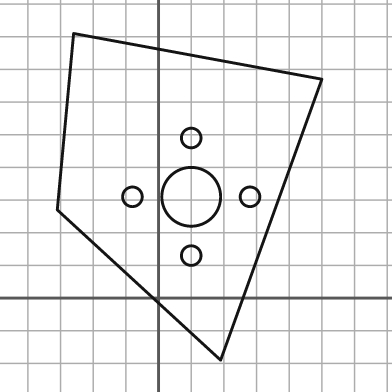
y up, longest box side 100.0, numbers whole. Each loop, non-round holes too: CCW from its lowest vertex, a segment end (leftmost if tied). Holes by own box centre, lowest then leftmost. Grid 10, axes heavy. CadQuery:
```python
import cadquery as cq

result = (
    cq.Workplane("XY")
    .moveTo(19.0, -19.0)
    .lineTo(50.0, 67.0)
    .lineTo(-26.0, 81.0)
    .lineTo(-31.0, 27.0)
    .close()
    .moveTo(10.0, 13.0)
    .circle(3.0)
    .moveTo(-8.0, 31.0)
    .circle(3.0)
    .moveTo(10.0, 31.0)
    .circle(9.0)
    .moveTo(28.0, 31.0)
    .circle(3.0)
    .moveTo(10.0, 49.0)
    .circle(3.0)
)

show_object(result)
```